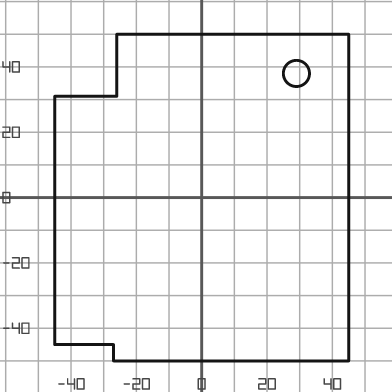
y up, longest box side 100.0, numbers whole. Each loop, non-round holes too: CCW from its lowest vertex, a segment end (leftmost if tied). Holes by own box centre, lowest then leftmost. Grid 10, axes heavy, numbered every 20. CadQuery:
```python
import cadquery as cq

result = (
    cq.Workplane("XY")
    .moveTo(-27.0, -50.0)
    .lineTo(45.0, -50.0)
    .lineTo(45.0, 50.0)
    .lineTo(-26.0, 50.0)
    .lineTo(-26.0, 31.0)
    .lineTo(-45.0, 31.0)
    .lineTo(-45.0, -45.0)
    .lineTo(-27.0, -45.0)
    .close()
    .moveTo(29.0, 38.0)
    .circle(4.0)
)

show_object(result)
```